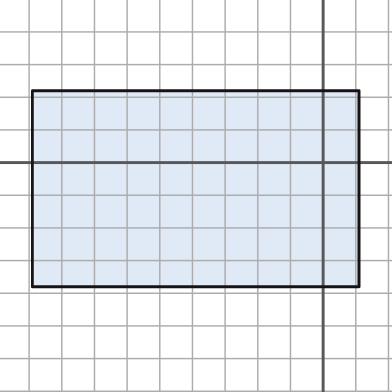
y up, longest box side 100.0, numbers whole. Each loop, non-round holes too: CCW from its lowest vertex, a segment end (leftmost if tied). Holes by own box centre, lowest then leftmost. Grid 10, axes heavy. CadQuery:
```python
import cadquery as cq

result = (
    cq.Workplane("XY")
    .moveTo(-89.0, -38.0)
    .lineTo(11.0, -38.0)
    .lineTo(11.0, 22.0)
    .lineTo(-89.0, 22.0)
    .close()
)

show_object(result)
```